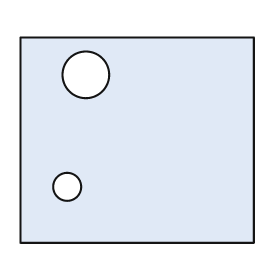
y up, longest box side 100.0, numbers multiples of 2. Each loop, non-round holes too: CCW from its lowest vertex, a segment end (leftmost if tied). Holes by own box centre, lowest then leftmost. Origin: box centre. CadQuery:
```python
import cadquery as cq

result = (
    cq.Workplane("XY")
    .moveTo(-50.0, -44.0)
    .lineTo(50.0, -44.0)
    .lineTo(50.0, 44.0)
    .lineTo(-50.0, 44.0)
    .close()
    .moveTo(-30.0, -20.0)
    .circle(6.0)
    .moveTo(-22.0, 28.0)
    .circle(10.0)
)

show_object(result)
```